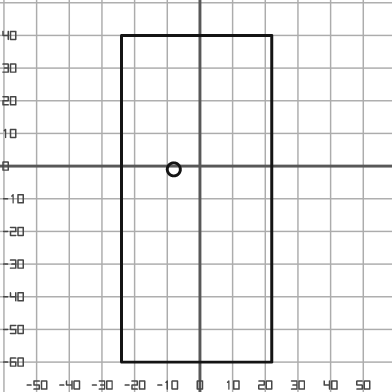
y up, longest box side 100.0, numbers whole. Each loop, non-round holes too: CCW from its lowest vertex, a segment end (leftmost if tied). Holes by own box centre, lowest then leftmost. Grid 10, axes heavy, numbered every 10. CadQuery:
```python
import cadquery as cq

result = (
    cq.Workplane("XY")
    .moveTo(-24.0, -60.0)
    .lineTo(22.0, -60.0)
    .lineTo(22.0, 40.0)
    .lineTo(-24.0, 40.0)
    .close()
    .moveTo(-8.0, -1.0)
    .circle(2.0)
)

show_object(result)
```